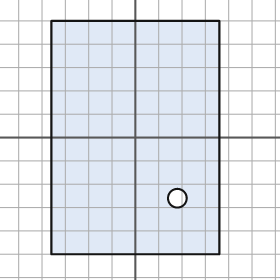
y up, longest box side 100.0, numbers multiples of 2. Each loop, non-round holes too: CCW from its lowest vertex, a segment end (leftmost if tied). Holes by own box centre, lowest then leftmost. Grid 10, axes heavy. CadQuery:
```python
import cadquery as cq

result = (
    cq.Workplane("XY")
    .moveTo(-36.0, -50.0)
    .lineTo(36.0, -50.0)
    .lineTo(36.0, 50.0)
    .lineTo(-36.0, 50.0)
    .close()
    .moveTo(18.0, -26.0)
    .circle(4.0)
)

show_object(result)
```